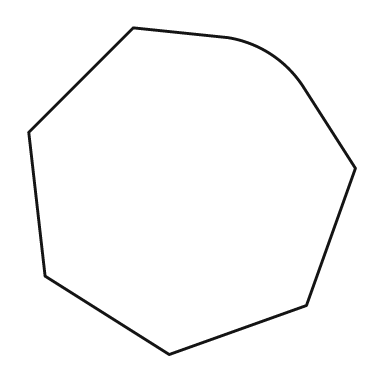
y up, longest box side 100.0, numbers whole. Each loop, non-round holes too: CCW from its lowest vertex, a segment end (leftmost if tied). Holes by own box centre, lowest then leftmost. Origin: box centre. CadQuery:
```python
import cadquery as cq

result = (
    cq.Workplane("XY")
    .moveTo(-7.0, -50.0)
    .lineTo(35.0, -35.0)
    .lineTo(50.0, 7.0)
    .lineTo(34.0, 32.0)
    .threePointArc((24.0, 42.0), (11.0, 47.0))
    .lineTo(-18.0, 50.0)
    .lineTo(-50.0, 18.0)
    .lineTo(-45.0, -26.0)
    .close()
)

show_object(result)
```